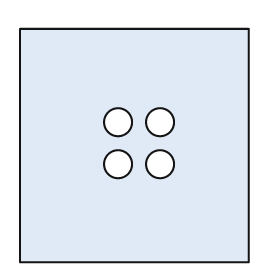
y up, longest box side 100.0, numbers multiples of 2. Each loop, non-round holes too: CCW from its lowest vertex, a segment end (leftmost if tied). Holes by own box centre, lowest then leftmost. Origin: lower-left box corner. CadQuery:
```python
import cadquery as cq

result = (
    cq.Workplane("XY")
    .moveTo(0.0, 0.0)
    .lineTo(98.0, 0.0)
    .lineTo(98.0, 100.0)
    .lineTo(0.0, 100.0)
    .close()
    .moveTo(42.0, 42.0)
    .circle(6.0)
    .moveTo(60.0, 42.0)
    .circle(6.0)
    .moveTo(42.0, 60.0)
    .circle(6.0)
    .moveTo(60.0, 60.0)
    .circle(6.0)
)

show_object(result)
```